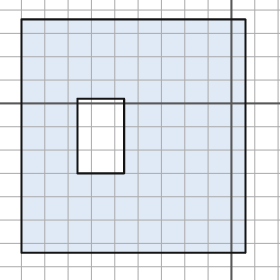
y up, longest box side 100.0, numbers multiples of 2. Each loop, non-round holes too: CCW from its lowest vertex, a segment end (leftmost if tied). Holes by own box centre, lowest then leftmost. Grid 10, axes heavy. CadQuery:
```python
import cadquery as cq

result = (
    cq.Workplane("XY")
    .moveTo(-90.0, -64.0)
    .lineTo(6.0, -64.0)
    .lineTo(6.0, 36.0)
    .lineTo(-90.0, 36.0)
    .close()
    .moveTo(-66.0, -30.0)
    .lineTo(-46.0, -30.0)
    .lineTo(-46.0, 2.0)
    .lineTo(-66.0, 2.0)
    .close()
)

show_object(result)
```